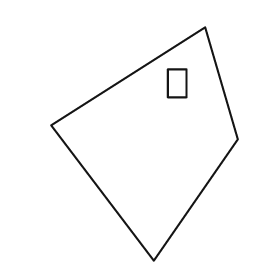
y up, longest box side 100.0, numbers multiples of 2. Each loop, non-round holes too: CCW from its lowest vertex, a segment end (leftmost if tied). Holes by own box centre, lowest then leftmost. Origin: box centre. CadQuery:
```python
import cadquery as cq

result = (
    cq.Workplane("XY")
    .moveTo(4.0, -50.0)
    .lineTo(40.0, 2.0)
    .lineTo(26.0, 50.0)
    .lineTo(-40.0, 8.0)
    .close()
    .moveTo(10.0, 20.0)
    .lineTo(18.0, 20.0)
    .lineTo(18.0, 32.0)
    .lineTo(10.0, 32.0)
    .close()
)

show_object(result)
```